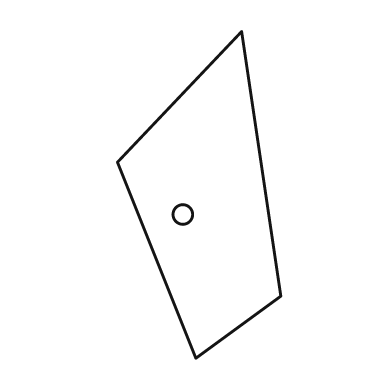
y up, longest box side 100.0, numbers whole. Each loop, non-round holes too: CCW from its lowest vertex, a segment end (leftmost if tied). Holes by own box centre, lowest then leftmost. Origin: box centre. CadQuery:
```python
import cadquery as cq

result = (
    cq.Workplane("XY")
    .moveTo(-1.0, -50.0)
    .lineTo(25.0, -31.0)
    .lineTo(13.0, 50.0)
    .lineTo(-25.0, 10.0)
    .close()
    .moveTo(-5.0, -6.0)
    .circle(3.0)
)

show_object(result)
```